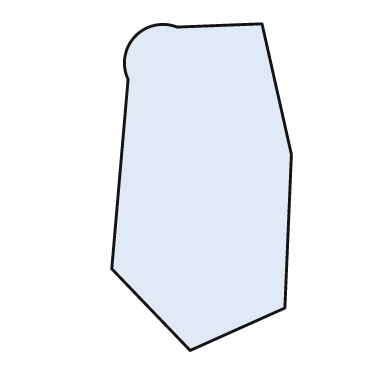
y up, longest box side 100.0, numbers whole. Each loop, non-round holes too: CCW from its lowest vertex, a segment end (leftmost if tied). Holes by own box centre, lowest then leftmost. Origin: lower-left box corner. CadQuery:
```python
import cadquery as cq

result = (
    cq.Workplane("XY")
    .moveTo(24.0, 0.0)
    .lineTo(53.0, 13.0)
    .lineTo(55.0, 60.0)
    .lineTo(46.0, 100.0)
    .lineTo(20.0, 99.0)
    .threePointArc((7.0, 96.0), (5.0, 83.0))
    .lineTo(0.0, 25.0)
    .close()
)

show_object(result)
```